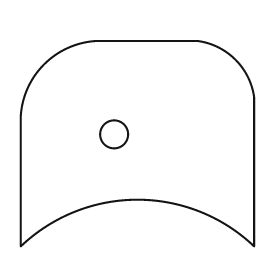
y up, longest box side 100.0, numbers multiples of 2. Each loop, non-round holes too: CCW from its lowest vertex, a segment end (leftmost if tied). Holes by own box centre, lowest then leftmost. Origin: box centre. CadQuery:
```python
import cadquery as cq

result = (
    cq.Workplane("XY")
    .moveTo(-50.0, -44.0)
    .threePointArc((0.0, -24.0), (50.0, -44.0))
    .lineTo(50.0, 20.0)
    .threePointArc((42.0, 36.0), (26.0, 44.0))
    .lineTo(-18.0, 44.0)
    .threePointArc((-40.0, 34.0), (-50.0, 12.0))
    .close()
    .moveTo(-10.0, 4.0)
    .circle(6.0)
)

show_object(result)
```